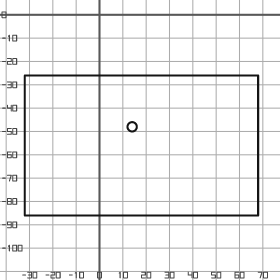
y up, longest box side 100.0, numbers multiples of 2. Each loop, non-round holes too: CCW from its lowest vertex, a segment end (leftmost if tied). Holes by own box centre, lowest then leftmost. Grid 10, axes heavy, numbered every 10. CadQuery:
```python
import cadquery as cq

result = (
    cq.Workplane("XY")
    .moveTo(-32.0, -86.0)
    .lineTo(68.0, -86.0)
    .lineTo(68.0, -26.0)
    .lineTo(-32.0, -26.0)
    .close()
    .moveTo(14.0, -48.0)
    .circle(2.0)
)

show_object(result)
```